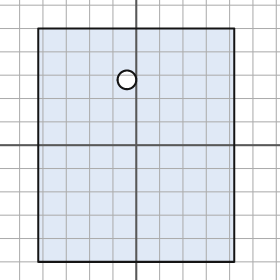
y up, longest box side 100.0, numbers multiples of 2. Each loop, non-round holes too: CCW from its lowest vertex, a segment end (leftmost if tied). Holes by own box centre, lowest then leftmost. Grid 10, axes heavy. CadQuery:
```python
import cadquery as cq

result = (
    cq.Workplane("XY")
    .moveTo(-42.0, -50.0)
    .lineTo(42.0, -50.0)
    .lineTo(42.0, 50.0)
    .lineTo(-42.0, 50.0)
    .close()
    .moveTo(-4.0, 28.0)
    .circle(4.0)
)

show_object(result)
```